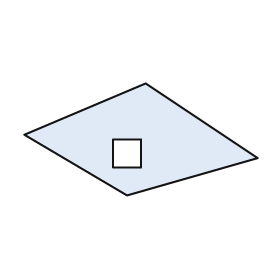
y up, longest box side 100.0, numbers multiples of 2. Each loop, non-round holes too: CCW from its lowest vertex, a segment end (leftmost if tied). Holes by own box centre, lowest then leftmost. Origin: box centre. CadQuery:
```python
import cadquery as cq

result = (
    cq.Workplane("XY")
    .moveTo(-6.0, -24.0)
    .lineTo(50.0, -8.0)
    .lineTo(2.0, 24.0)
    .lineTo(-50.0, 2.0)
    .close()
    .moveTo(-12.0, -12.0)
    .lineTo(0.0, -12.0)
    .lineTo(0.0, 0.0)
    .lineTo(-12.0, 0.0)
    .close()
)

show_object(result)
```